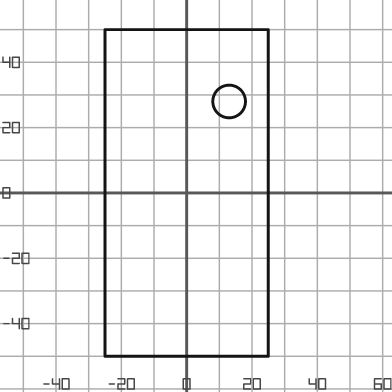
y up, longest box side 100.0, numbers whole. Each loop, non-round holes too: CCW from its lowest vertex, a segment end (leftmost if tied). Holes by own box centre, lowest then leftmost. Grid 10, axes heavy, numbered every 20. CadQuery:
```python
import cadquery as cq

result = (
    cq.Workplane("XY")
    .moveTo(-25.0, -50.0)
    .lineTo(25.0, -50.0)
    .lineTo(25.0, 50.0)
    .lineTo(-25.0, 50.0)
    .close()
    .moveTo(13.0, 28.0)
    .circle(5.0)
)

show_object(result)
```